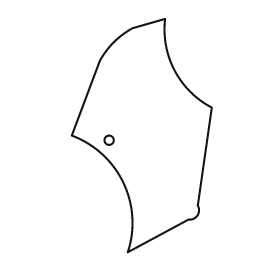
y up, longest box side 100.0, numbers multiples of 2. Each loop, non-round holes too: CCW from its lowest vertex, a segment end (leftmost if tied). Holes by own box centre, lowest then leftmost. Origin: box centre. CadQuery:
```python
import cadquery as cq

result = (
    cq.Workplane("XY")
    .moveTo(-6.0, -50.0)
    .lineTo(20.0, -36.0)
    .threePointArc((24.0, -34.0), (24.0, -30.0))
    .lineTo(30.0, 12.0)
    .threePointArc((14.0, 28.0), (10.0, 50.0))
    .lineTo(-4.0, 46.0)
    .threePointArc((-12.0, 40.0), (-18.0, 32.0))
    .lineTo(-30.0, 0.0)
    .threePointArc((-8.0, -20.0), (-6.0, -50.0))
    .close()
    .moveTo(-14.0, -2.0)
    .circle(2.0)
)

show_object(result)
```